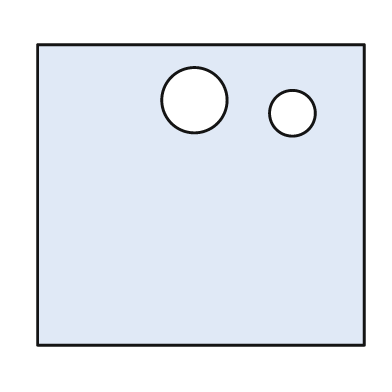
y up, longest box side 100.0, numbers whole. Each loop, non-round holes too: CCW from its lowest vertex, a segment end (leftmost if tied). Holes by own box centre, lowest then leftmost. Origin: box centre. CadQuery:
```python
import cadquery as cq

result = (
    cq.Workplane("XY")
    .moveTo(-50.0, -46.0)
    .lineTo(50.0, -46.0)
    .lineTo(50.0, 46.0)
    .lineTo(-50.0, 46.0)
    .close()
    .moveTo(28.0, 25.0)
    .circle(7.0)
    .moveTo(-2.0, 29.0)
    .circle(10.0)
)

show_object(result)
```